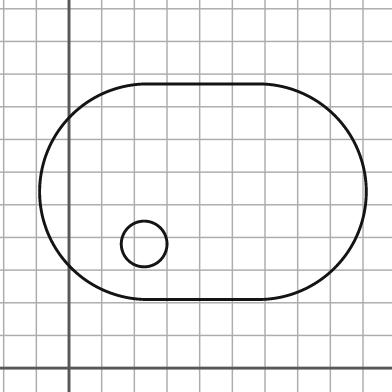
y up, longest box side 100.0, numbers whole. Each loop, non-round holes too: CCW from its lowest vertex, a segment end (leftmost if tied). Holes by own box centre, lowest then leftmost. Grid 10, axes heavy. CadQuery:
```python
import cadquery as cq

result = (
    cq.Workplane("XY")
    .moveTo(24.0, 21.0)
    .lineTo(58.0, 21.0)
    .threePointArc((91.0, 54.0), (58.0, 87.0))
    .lineTo(24.0, 87.0)
    .threePointArc((-9.0, 54.0), (24.0, 21.0))
    .close()
    .moveTo(23.0, 38.0)
    .circle(7.0)
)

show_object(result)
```